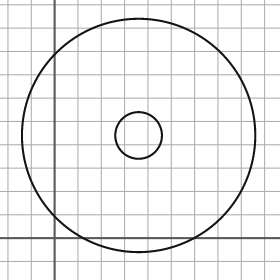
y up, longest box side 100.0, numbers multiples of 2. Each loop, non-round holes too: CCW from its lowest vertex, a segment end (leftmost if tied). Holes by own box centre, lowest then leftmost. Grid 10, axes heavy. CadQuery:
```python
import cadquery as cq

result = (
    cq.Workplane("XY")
    .moveTo(36.0, 44.0)
    .circle(50.0)
    .moveTo(36.0, 44.0)
    .circle(10.0)
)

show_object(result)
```